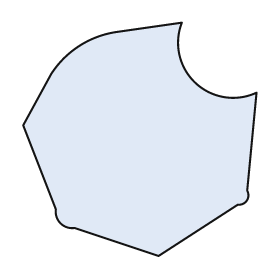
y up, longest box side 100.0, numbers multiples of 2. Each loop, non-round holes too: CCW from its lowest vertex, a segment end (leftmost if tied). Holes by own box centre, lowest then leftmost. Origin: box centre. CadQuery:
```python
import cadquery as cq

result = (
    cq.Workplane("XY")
    .moveTo(8.0, -50.0)
    .lineTo(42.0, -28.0)
    .threePointArc((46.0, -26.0), (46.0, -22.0))
    .lineTo(50.0, 20.0)
    .threePointArc((24.0, 24.0), (18.0, 50.0))
    .lineTo(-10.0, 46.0)
    .threePointArc((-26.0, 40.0), (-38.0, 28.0))
    .lineTo(-50.0, 6.0)
    .lineTo(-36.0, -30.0)
    .threePointArc((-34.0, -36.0), (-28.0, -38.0))
    .close()
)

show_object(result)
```